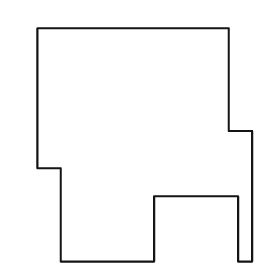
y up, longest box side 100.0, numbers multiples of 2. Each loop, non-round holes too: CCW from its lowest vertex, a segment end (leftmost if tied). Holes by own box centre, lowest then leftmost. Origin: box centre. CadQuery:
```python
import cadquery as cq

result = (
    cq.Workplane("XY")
    .moveTo(-36.0, -50.0)
    .lineTo(4.0, -50.0)
    .lineTo(4.0, -22.0)
    .lineTo(40.0, -22.0)
    .lineTo(40.0, -50.0)
    .lineTo(46.0, -50.0)
    .lineTo(46.0, 6.0)
    .lineTo(36.0, 6.0)
    .lineTo(36.0, 50.0)
    .lineTo(-46.0, 50.0)
    .lineTo(-46.0, -10.0)
    .lineTo(-36.0, -10.0)
    .close()
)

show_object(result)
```